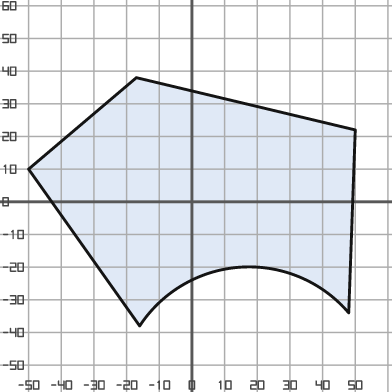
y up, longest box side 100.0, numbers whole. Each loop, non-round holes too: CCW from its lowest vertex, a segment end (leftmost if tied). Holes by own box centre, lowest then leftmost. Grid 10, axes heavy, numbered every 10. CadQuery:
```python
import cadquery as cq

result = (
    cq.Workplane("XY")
    .moveTo(-16.0, -38.0)
    .threePointArc((15.0, -20.0), (48.0, -34.0))
    .lineTo(50.0, 22.0)
    .lineTo(-17.0, 38.0)
    .lineTo(-50.0, 10.0)
    .close()
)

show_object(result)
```